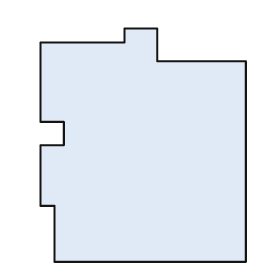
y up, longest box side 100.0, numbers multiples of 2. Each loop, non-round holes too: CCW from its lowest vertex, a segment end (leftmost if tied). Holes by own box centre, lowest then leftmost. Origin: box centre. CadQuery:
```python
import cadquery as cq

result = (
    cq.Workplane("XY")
    .moveTo(-38.0, -50.0)
    .lineTo(44.0, -50.0)
    .lineTo(44.0, 36.0)
    .lineTo(6.0, 36.0)
    .lineTo(6.0, 50.0)
    .lineTo(-8.0, 50.0)
    .lineTo(-8.0, 44.0)
    .lineTo(-44.0, 44.0)
    .lineTo(-44.0, 10.0)
    .lineTo(-34.0, 10.0)
    .lineTo(-34.0, 0.0)
    .lineTo(-44.0, 0.0)
    .lineTo(-44.0, -26.0)
    .lineTo(-38.0, -26.0)
    .close()
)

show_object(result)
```